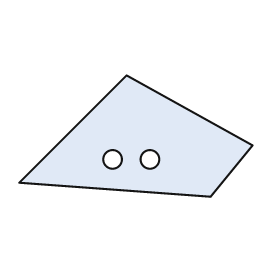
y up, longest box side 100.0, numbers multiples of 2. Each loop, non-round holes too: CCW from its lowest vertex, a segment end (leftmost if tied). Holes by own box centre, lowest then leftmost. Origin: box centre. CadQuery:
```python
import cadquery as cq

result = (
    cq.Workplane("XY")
    .moveTo(32.0, -26.0)
    .lineTo(50.0, -4.0)
    .lineTo(-4.0, 26.0)
    .lineTo(-50.0, -20.0)
    .close()
    .moveTo(-10.0, -10.0)
    .circle(4.0)
    .moveTo(6.0, -10.0)
    .circle(4.0)
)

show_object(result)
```